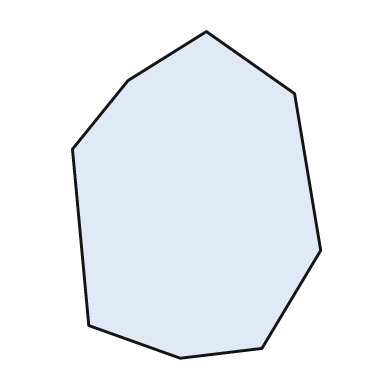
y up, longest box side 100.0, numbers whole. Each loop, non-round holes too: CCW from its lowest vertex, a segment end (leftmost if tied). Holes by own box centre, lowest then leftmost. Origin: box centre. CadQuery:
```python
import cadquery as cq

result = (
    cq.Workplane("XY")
    .moveTo(-5.0, -50.0)
    .lineTo(20.0, -47.0)
    .lineTo(38.0, -17.0)
    .lineTo(30.0, 31.0)
    .lineTo(3.0, 50.0)
    .lineTo(-21.0, 35.0)
    .lineTo(-38.0, 14.0)
    .lineTo(-33.0, -40.0)
    .close()
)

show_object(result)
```